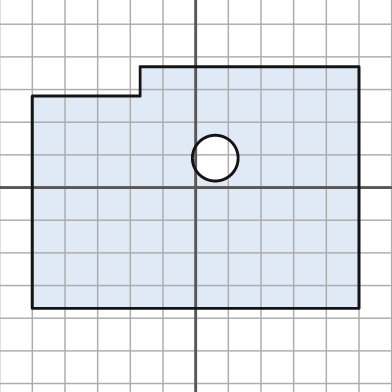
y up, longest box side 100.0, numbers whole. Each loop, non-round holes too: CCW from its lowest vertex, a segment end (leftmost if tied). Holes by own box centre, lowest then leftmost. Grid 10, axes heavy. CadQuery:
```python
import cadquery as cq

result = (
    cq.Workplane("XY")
    .moveTo(-50.0, -37.0)
    .lineTo(50.0, -37.0)
    .lineTo(50.0, 37.0)
    .lineTo(-17.0, 37.0)
    .lineTo(-17.0, 28.0)
    .lineTo(-50.0, 28.0)
    .close()
    .moveTo(6.0, 9.0)
    .circle(7.0)
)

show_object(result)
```